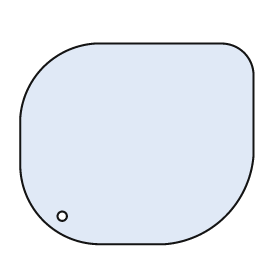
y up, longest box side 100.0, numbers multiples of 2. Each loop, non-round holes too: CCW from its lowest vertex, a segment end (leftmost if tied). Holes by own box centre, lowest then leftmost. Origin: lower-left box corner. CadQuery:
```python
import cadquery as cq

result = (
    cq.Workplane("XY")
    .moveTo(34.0, 0.0)
    .lineTo(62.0, 0.0)
    .threePointArc((88.0, 12.0), (100.0, 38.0))
    .lineTo(100.0, 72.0)
    .threePointArc((96.0, 82.0), (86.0, 86.0))
    .lineTo(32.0, 86.0)
    .threePointArc((10.0, 76.0), (0.0, 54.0))
    .lineTo(0.0, 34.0)
    .threePointArc((10.0, 10.0), (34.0, 0.0))
    .close()
    .moveTo(18.0, 12.0)
    .circle(2.0)
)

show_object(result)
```